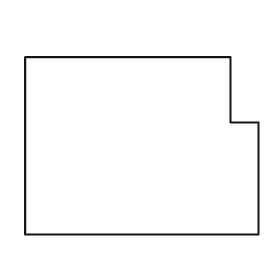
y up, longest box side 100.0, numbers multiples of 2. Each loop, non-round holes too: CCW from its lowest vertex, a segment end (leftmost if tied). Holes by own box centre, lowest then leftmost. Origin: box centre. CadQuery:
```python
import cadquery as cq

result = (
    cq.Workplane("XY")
    .moveTo(-50.0, -38.0)
    .lineTo(50.0, -38.0)
    .lineTo(50.0, 10.0)
    .lineTo(38.0, 10.0)
    .lineTo(38.0, 38.0)
    .lineTo(-50.0, 38.0)
    .close()
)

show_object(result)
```